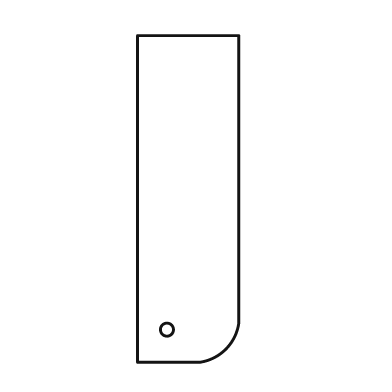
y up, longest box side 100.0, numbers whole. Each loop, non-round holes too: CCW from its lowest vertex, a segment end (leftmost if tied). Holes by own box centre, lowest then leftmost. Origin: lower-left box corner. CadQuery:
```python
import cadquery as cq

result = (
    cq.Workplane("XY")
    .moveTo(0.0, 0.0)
    .lineTo(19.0, 0.0)
    .threePointArc((27.0, 4.0), (31.0, 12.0))
    .lineTo(31.0, 100.0)
    .lineTo(0.0, 100.0)
    .close()
    .moveTo(9.0, 10.0)
    .circle(2.0)
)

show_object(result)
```